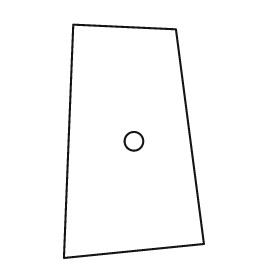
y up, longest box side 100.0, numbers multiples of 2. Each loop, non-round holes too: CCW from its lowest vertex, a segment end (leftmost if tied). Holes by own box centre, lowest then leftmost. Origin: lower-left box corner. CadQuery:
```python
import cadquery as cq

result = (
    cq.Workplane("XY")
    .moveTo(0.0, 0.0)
    .lineTo(60.0, 6.0)
    .lineTo(48.0, 98.0)
    .lineTo(4.0, 100.0)
    .close()
    .moveTo(30.0, 50.0)
    .circle(4.0)
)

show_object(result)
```